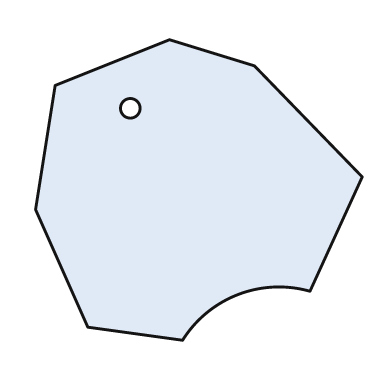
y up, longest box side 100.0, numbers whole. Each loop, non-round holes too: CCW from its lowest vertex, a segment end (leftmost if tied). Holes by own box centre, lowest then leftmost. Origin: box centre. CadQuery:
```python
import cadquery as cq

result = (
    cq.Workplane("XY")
    .moveTo(-5.0, -46.0)
    .threePointArc((12.0, -32.0), (34.0, -31.0))
    .lineTo(50.0, 4.0)
    .lineTo(17.0, 38.0)
    .lineTo(-9.0, 46.0)
    .lineTo(-44.0, 32.0)
    .lineTo(-50.0, -6.0)
    .lineTo(-34.0, -42.0)
    .close()
    .moveTo(-21.0, 25.0)
    .circle(3.0)
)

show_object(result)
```